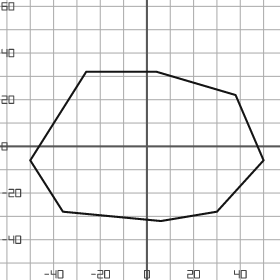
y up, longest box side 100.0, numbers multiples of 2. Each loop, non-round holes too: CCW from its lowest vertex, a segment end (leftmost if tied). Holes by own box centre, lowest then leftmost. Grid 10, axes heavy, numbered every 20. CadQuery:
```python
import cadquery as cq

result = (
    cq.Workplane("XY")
    .moveTo(6.0, -32.0)
    .lineTo(30.0, -28.0)
    .lineTo(50.0, -6.0)
    .lineTo(38.0, 22.0)
    .lineTo(4.0, 32.0)
    .lineTo(-26.0, 32.0)
    .lineTo(-50.0, -6.0)
    .lineTo(-36.0, -28.0)
    .close()
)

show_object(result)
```